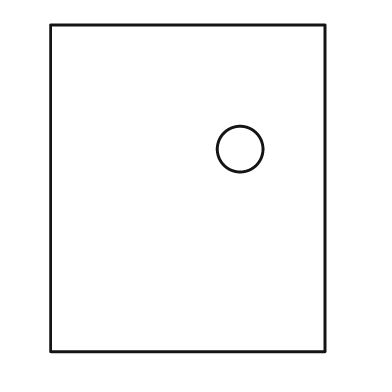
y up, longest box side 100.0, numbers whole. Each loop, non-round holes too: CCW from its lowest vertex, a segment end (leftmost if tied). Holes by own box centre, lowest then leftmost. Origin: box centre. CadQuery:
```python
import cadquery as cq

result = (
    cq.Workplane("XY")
    .moveTo(-42.0, -50.0)
    .lineTo(42.0, -50.0)
    .lineTo(42.0, 50.0)
    .lineTo(-42.0, 50.0)
    .close()
    .moveTo(16.0, 12.0)
    .circle(7.0)
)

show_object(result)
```